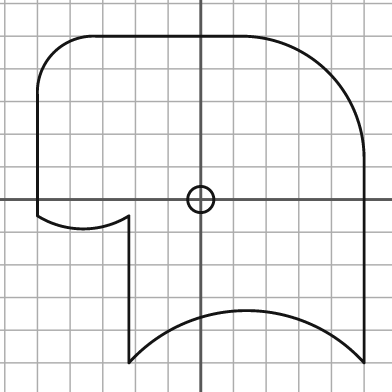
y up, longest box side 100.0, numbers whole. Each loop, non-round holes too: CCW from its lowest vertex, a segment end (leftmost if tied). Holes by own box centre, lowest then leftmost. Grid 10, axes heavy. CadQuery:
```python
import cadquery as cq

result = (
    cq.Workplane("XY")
    .moveTo(-22.0, -50.0)
    .threePointArc((14.0, -34.0), (50.0, -50.0))
    .lineTo(50.0, 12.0)
    .threePointArc((39.0, 39.0), (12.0, 50.0))
    .lineTo(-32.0, 50.0)
    .threePointArc((-45.0, 45.0), (-50.0, 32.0))
    .lineTo(-50.0, -5.0)
    .threePointArc((-36.0, -9.0), (-22.0, -5.0))
    .close()
    .moveTo(0.0, 0.0)
    .circle(4.0)
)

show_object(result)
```